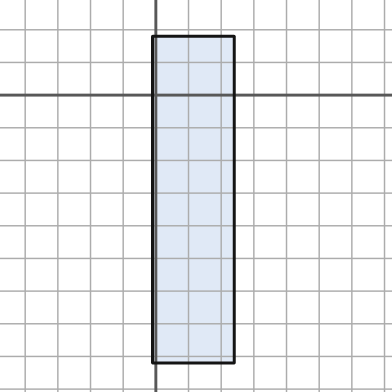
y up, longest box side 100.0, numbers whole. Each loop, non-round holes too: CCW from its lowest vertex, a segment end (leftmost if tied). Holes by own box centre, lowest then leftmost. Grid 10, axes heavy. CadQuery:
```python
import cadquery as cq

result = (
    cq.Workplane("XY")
    .moveTo(-1.0, -82.0)
    .lineTo(24.0, -82.0)
    .lineTo(24.0, 18.0)
    .lineTo(-1.0, 18.0)
    .close()
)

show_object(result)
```